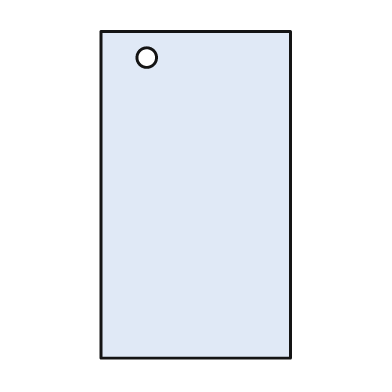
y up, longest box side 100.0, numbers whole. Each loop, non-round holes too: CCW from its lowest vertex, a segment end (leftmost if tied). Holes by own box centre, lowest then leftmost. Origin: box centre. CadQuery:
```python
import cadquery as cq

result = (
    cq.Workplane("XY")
    .moveTo(-29.0, -50.0)
    .lineTo(29.0, -50.0)
    .lineTo(29.0, 50.0)
    .lineTo(-29.0, 50.0)
    .close()
    .moveTo(-15.0, 42.0)
    .circle(3.0)
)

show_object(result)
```